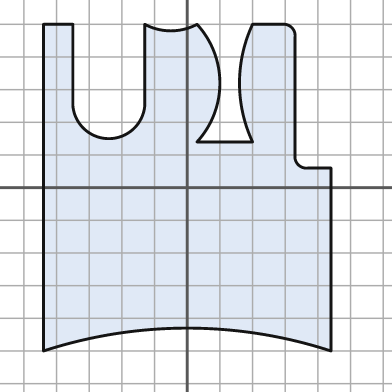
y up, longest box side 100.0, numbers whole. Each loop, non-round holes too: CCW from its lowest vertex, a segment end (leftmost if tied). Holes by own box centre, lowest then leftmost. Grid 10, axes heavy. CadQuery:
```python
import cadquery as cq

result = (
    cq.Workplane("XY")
    .moveTo(-44.0, -50.0)
    .threePointArc((0.0, -43.0), (44.0, -50.0))
    .lineTo(44.0, 6.0)
    .lineTo(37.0, 6.0)
    .threePointArc((34.0, 7.0), (33.0, 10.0))
    .lineTo(33.0, 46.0)
    .threePointArc((32.0, 49.0), (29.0, 50.0))
    .lineTo(20.0, 50.0)
    .threePointArc((16.0, 32.0), (20.0, 14.0))
    .lineTo(3.0, 14.0)
    .threePointArc((10.0, 32.0), (3.0, 50.0))
    .threePointArc((-5.0, 48.0), (-13.0, 50.0))
    .lineTo(-13.0, 25.0)
    .threePointArc((-24.0, 15.0), (-35.0, 25.0))
    .lineTo(-35.0, 50.0)
    .lineTo(-44.0, 50.0)
    .close()
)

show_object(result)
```